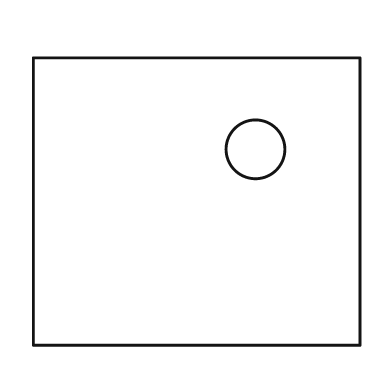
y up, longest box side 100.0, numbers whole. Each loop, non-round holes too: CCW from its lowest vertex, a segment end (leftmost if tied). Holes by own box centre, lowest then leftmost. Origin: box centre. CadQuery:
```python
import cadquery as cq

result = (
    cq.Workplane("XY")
    .moveTo(-50.0, -44.0)
    .lineTo(50.0, -44.0)
    .lineTo(50.0, 44.0)
    .lineTo(-50.0, 44.0)
    .close()
    .moveTo(18.0, 16.0)
    .circle(9.0)
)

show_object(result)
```